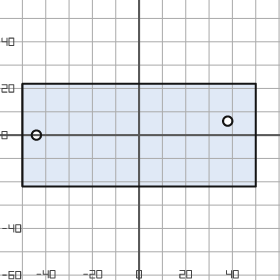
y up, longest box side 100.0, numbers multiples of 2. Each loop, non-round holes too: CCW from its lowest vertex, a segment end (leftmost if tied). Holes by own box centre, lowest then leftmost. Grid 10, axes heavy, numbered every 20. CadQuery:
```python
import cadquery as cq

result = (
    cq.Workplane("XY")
    .moveTo(-50.0, -22.0)
    .lineTo(50.0, -22.0)
    .lineTo(50.0, 22.0)
    .lineTo(-50.0, 22.0)
    .close()
    .moveTo(-44.0, 0.0)
    .circle(2.0)
    .moveTo(38.0, 6.0)
    .circle(2.0)
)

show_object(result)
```